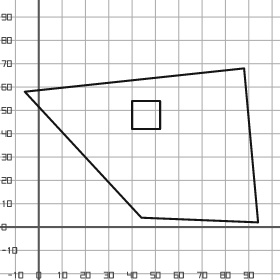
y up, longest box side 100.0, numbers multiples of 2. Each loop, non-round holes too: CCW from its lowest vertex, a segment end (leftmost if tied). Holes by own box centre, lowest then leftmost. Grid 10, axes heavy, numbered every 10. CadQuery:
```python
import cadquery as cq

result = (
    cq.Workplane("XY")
    .moveTo(94.0, 2.0)
    .lineTo(88.0, 68.0)
    .lineTo(-6.0, 58.0)
    .lineTo(44.0, 4.0)
    .close()
    .moveTo(40.0, 42.0)
    .lineTo(52.0, 42.0)
    .lineTo(52.0, 54.0)
    .lineTo(40.0, 54.0)
    .close()
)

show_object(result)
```